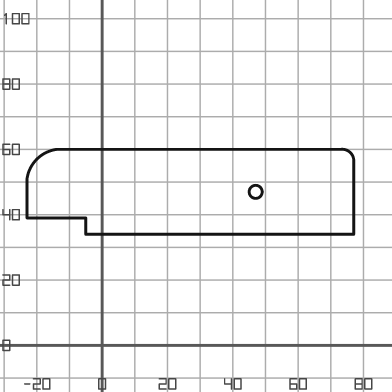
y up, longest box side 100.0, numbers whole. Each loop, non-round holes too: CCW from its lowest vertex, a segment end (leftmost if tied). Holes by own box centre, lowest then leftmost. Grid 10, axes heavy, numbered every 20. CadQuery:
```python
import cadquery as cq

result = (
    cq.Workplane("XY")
    .moveTo(-5.0, 34.0)
    .lineTo(77.0, 34.0)
    .lineTo(77.0, 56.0)
    .threePointArc((76.0, 59.0), (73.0, 60.0))
    .lineTo(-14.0, 60.0)
    .threePointArc((-20.0, 57.0), (-23.0, 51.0))
    .lineTo(-23.0, 39.0)
    .lineTo(-5.0, 39.0)
    .close()
    .moveTo(47.0, 47.0)
    .circle(2.0)
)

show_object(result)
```